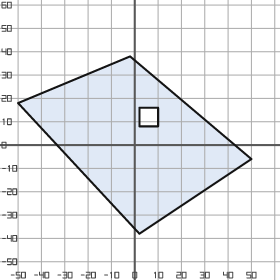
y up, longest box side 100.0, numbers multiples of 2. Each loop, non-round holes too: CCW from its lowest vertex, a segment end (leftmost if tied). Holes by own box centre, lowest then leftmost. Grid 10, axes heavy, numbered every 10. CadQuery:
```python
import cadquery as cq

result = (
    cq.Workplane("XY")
    .moveTo(2.0, -38.0)
    .lineTo(50.0, -6.0)
    .lineTo(-2.0, 38.0)
    .lineTo(-50.0, 18.0)
    .close()
    .moveTo(2.0, 8.0)
    .lineTo(10.0, 8.0)
    .lineTo(10.0, 16.0)
    .lineTo(2.0, 16.0)
    .close()
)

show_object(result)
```